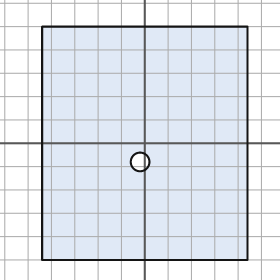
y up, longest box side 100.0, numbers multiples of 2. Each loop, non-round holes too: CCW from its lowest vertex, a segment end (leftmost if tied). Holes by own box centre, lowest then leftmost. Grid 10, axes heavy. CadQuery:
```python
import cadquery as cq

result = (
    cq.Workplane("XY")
    .moveTo(-44.0, -50.0)
    .lineTo(44.0, -50.0)
    .lineTo(44.0, 50.0)
    .lineTo(-44.0, 50.0)
    .close()
    .moveTo(-2.0, -8.0)
    .circle(4.0)
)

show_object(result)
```